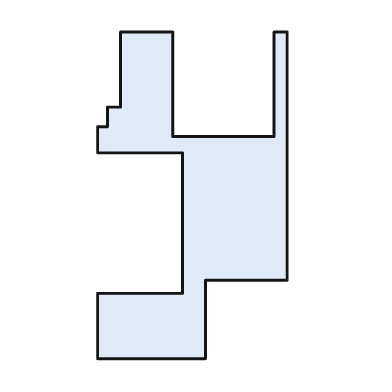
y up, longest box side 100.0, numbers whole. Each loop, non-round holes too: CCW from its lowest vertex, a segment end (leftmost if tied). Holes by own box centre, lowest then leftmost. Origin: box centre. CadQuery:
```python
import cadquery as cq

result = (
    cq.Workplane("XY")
    .moveTo(-29.0, -50.0)
    .lineTo(4.0, -50.0)
    .lineTo(4.0, -26.0)
    .lineTo(29.0, -26.0)
    .lineTo(29.0, 50.0)
    .lineTo(25.0, 50.0)
    .lineTo(25.0, 18.0)
    .lineTo(-6.0, 18.0)
    .lineTo(-6.0, 50.0)
    .lineTo(-22.0, 50.0)
    .lineTo(-22.0, 27.0)
    .lineTo(-26.0, 27.0)
    .lineTo(-26.0, 21.0)
    .lineTo(-29.0, 21.0)
    .lineTo(-29.0, 13.0)
    .lineTo(-3.0, 13.0)
    .lineTo(-3.0, -30.0)
    .lineTo(-29.0, -30.0)
    .close()
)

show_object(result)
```